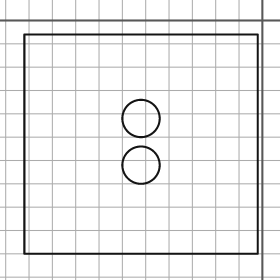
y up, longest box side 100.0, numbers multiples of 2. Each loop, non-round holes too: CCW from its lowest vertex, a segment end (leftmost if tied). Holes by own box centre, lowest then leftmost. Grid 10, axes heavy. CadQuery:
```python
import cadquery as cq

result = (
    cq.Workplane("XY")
    .moveTo(-102.0, -100.0)
    .lineTo(-2.0, -100.0)
    .lineTo(-2.0, -6.0)
    .lineTo(-102.0, -6.0)
    .close()
    .moveTo(-52.0, -62.0)
    .circle(8.0)
    .moveTo(-52.0, -42.0)
    .circle(8.0)
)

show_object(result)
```